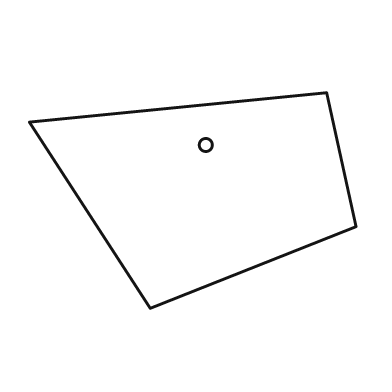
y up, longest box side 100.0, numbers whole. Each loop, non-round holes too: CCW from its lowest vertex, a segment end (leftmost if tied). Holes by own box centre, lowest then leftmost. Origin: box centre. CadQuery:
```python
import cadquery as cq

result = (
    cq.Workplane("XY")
    .moveTo(-13.0, -33.0)
    .lineTo(50.0, -8.0)
    .lineTo(41.0, 33.0)
    .lineTo(-50.0, 24.0)
    .close()
    .moveTo(4.0, 17.0)
    .circle(2.0)
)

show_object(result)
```